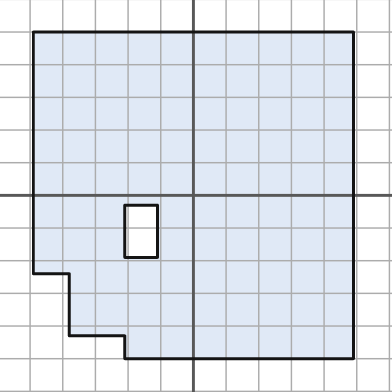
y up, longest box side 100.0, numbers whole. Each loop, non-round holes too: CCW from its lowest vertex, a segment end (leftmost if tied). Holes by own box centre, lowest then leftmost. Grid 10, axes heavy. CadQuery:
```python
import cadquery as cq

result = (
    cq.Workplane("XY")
    .moveTo(-21.0, -50.0)
    .lineTo(49.0, -50.0)
    .lineTo(49.0, 50.0)
    .lineTo(-49.0, 50.0)
    .lineTo(-49.0, -24.0)
    .lineTo(-38.0, -24.0)
    .lineTo(-38.0, -43.0)
    .lineTo(-21.0, -43.0)
    .close()
    .moveTo(-21.0, -19.0)
    .lineTo(-11.0, -19.0)
    .lineTo(-11.0, -3.0)
    .lineTo(-21.0, -3.0)
    .close()
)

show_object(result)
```